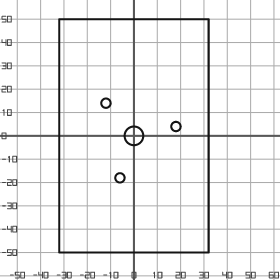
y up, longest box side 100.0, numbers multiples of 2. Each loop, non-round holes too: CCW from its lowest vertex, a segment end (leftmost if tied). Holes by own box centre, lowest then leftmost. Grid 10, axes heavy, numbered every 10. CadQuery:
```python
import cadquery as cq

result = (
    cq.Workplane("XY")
    .moveTo(-32.0, -50.0)
    .lineTo(32.0, -50.0)
    .lineTo(32.0, 50.0)
    .lineTo(-32.0, 50.0)
    .close()
    .moveTo(-6.0, -18.0)
    .circle(2.0)
    .moveTo(0.0, 0.0)
    .circle(4.0)
    .moveTo(18.0, 4.0)
    .circle(2.0)
    .moveTo(-12.0, 14.0)
    .circle(2.0)
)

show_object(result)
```